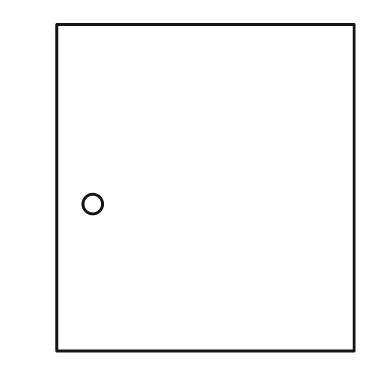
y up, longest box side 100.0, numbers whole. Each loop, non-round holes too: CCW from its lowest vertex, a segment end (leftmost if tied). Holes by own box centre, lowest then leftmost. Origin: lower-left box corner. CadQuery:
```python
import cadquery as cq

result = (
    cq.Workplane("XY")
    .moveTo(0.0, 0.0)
    .lineTo(91.0, 0.0)
    .lineTo(91.0, 100.0)
    .lineTo(0.0, 100.0)
    .close()
    .moveTo(11.0, 45.0)
    .circle(3.0)
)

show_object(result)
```